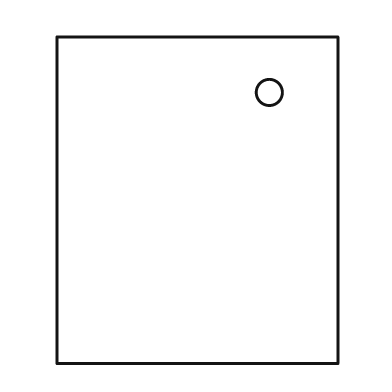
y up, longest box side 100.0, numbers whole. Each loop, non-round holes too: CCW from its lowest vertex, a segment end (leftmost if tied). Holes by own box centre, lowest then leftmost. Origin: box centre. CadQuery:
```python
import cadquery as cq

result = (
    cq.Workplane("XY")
    .moveTo(-43.0, -50.0)
    .lineTo(43.0, -50.0)
    .lineTo(43.0, 50.0)
    .lineTo(-43.0, 50.0)
    .close()
    .moveTo(22.0, 33.0)
    .circle(4.0)
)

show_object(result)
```